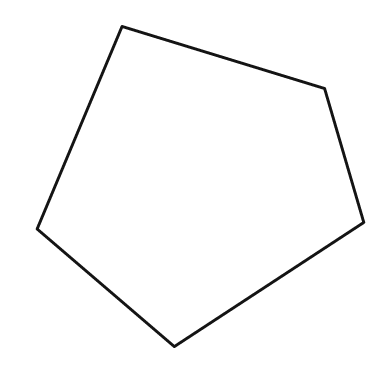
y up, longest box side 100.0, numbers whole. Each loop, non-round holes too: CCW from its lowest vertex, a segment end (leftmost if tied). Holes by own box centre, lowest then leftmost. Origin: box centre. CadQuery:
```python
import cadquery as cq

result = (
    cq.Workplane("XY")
    .moveTo(-8.0, -49.0)
    .lineTo(50.0, -11.0)
    .lineTo(38.0, 30.0)
    .lineTo(-24.0, 49.0)
    .lineTo(-50.0, -13.0)
    .close()
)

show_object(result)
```